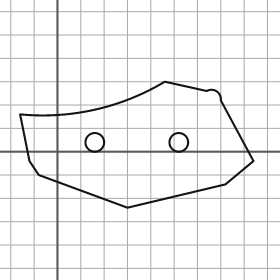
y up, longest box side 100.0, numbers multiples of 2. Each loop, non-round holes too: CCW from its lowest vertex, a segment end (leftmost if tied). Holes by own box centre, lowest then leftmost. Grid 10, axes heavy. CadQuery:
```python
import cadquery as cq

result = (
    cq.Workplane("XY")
    .moveTo(30.0, -24.0)
    .lineTo(72.0, -14.0)
    .lineTo(84.0, -4.0)
    .lineTo(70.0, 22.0)
    .threePointArc((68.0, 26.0), (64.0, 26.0))
    .lineTo(46.0, 30.0)
    .threePointArc((16.0, 18.0), (-16.0, 16.0))
    .lineTo(-12.0, -4.0)
    .lineTo(-8.0, -10.0)
    .close()
    .moveTo(16.0, 4.0)
    .circle(4.0)
    .moveTo(52.0, 4.0)
    .circle(4.0)
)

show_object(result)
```